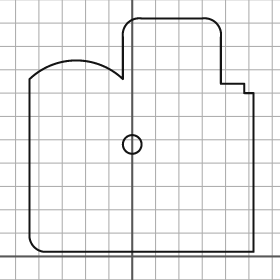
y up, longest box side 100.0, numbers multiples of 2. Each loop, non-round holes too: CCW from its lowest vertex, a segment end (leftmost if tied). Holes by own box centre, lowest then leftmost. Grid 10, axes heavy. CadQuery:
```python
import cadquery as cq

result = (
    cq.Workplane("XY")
    .moveTo(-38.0, 2.0)
    .lineTo(52.0, 2.0)
    .lineTo(52.0, 70.0)
    .lineTo(48.0, 70.0)
    .lineTo(48.0, 74.0)
    .lineTo(38.0, 74.0)
    .lineTo(38.0, 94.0)
    .threePointArc((36.0, 100.0), (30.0, 102.0))
    .lineTo(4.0, 102.0)
    .threePointArc((-2.0, 100.0), (-4.0, 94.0))
    .lineTo(-4.0, 76.0)
    .threePointArc((-24.0, 84.0), (-44.0, 76.0))
    .lineTo(-44.0, 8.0)
    .threePointArc((-42.0, 4.0), (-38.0, 2.0))
    .close()
    .moveTo(0.0, 48.0)
    .circle(4.0)
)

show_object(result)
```